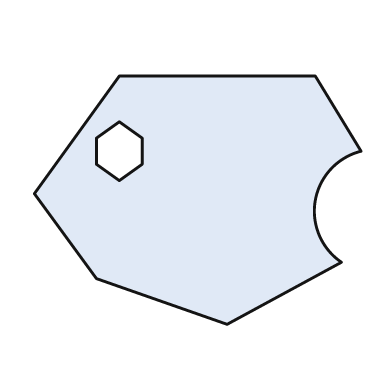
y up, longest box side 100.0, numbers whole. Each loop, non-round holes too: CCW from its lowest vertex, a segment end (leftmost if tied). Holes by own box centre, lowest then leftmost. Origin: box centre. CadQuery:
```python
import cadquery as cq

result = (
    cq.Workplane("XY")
    .moveTo(9.0, -38.0)
    .lineTo(44.0, -19.0)
    .threePointArc((36.0, 0.0), (50.0, 15.0))
    .lineTo(36.0, 38.0)
    .lineTo(-24.0, 38.0)
    .lineTo(-50.0, 2.0)
    .lineTo(-31.0, -24.0)
    .close()
    .moveTo(-24.0, 6.0)
    .lineTo(-17.0, 11.0)
    .lineTo(-17.0, 19.0)
    .lineTo(-24.0, 24.0)
    .lineTo(-31.0, 19.0)
    .lineTo(-31.0, 11.0)
    .close()
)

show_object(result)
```